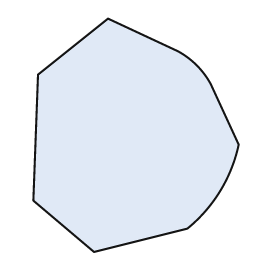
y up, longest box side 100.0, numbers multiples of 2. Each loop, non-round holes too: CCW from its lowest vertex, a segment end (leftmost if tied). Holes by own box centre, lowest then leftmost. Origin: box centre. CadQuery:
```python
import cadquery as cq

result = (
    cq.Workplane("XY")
    .moveTo(-18.0, -50.0)
    .lineTo(22.0, -40.0)
    .threePointArc((36.0, -24.0), (44.0, -4.0))
    .lineTo(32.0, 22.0)
    .threePointArc((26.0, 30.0), (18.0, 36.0))
    .lineTo(-12.0, 50.0)
    .lineTo(-42.0, 26.0)
    .lineTo(-44.0, -28.0)
    .close()
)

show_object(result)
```